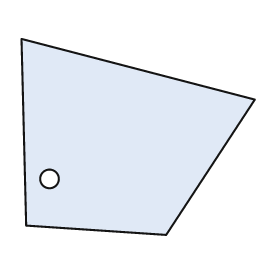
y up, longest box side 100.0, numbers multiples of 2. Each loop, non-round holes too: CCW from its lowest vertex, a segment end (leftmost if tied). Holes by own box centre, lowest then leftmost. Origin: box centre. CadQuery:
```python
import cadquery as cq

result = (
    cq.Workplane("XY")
    .moveTo(12.0, -42.0)
    .lineTo(50.0, 16.0)
    .lineTo(-50.0, 42.0)
    .lineTo(-48.0, -38.0)
    .close()
    .moveTo(-38.0, -18.0)
    .circle(4.0)
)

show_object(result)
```